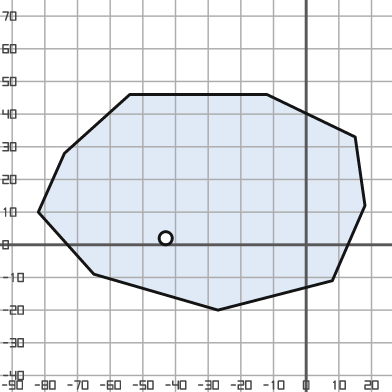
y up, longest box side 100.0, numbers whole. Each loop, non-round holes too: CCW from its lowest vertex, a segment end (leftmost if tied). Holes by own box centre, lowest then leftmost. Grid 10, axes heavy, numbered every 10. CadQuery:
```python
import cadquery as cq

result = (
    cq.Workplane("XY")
    .moveTo(-27.0, -20.0)
    .lineTo(8.0, -11.0)
    .lineTo(18.0, 12.0)
    .lineTo(15.0, 33.0)
    .lineTo(-12.0, 46.0)
    .lineTo(-54.0, 46.0)
    .lineTo(-74.0, 28.0)
    .lineTo(-82.0, 10.0)
    .lineTo(-65.0, -9.0)
    .close()
    .moveTo(-43.0, 2.0)
    .circle(2.0)
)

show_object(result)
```